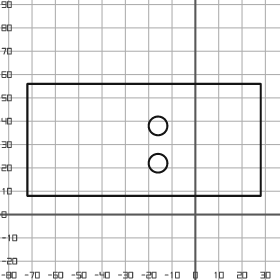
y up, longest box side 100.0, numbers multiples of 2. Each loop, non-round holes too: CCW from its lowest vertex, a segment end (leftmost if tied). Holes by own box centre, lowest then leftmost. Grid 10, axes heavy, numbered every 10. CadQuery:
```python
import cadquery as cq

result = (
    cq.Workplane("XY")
    .moveTo(-72.0, 8.0)
    .lineTo(28.0, 8.0)
    .lineTo(28.0, 56.0)
    .lineTo(-72.0, 56.0)
    .close()
    .moveTo(-16.0, 22.0)
    .circle(4.0)
    .moveTo(-16.0, 38.0)
    .circle(4.0)
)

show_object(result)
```